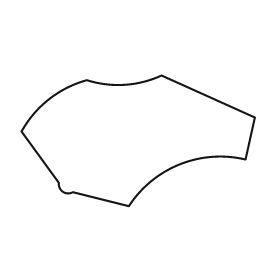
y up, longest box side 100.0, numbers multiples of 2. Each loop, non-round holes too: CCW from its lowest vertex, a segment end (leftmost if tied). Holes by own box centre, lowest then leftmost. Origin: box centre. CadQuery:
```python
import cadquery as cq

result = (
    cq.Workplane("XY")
    .moveTo(-4.0, -28.0)
    .threePointArc((18.0, -10.0), (46.0, -8.0))
    .lineTo(50.0, 10.0)
    .lineTo(10.0, 28.0)
    .threePointArc((-6.0, 24.0), (-22.0, 26.0))
    .threePointArc((-38.0, 18.0), (-50.0, 4.0))
    .lineTo(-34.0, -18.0)
    .threePointArc((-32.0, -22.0), (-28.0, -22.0))
    .close()
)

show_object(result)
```